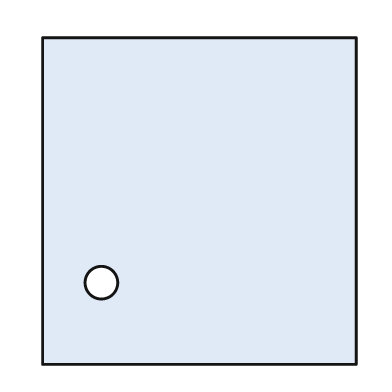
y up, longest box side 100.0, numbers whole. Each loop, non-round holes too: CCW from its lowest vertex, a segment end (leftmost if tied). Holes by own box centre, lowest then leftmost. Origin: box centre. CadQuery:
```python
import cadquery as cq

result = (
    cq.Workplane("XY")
    .moveTo(-48.0, -50.0)
    .lineTo(48.0, -50.0)
    .lineTo(48.0, 50.0)
    .lineTo(-48.0, 50.0)
    .close()
    .moveTo(-30.0, -25.0)
    .circle(5.0)
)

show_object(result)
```